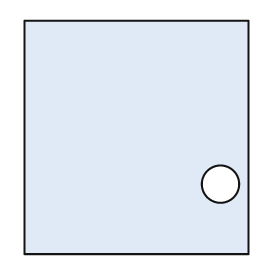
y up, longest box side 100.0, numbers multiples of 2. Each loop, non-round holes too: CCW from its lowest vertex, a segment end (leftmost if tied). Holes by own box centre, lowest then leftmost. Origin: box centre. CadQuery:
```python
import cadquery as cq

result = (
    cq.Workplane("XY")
    .moveTo(-48.0, -50.0)
    .lineTo(48.0, -50.0)
    .lineTo(48.0, 50.0)
    .lineTo(-48.0, 50.0)
    .close()
    .moveTo(36.0, -20.0)
    .circle(8.0)
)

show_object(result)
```